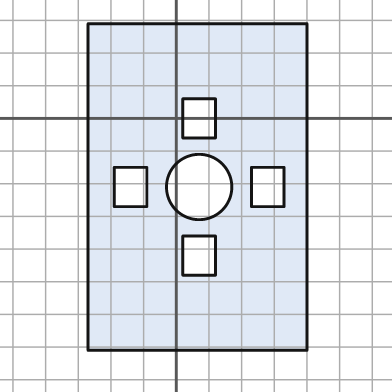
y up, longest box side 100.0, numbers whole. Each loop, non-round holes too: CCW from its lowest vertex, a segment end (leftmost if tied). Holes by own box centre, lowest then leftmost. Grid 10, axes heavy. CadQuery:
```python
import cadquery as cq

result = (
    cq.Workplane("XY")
    .moveTo(-27.0, -71.0)
    .lineTo(40.0, -71.0)
    .lineTo(40.0, 29.0)
    .lineTo(-27.0, 29.0)
    .close()
    .moveTo(2.0, -48.0)
    .lineTo(12.0, -48.0)
    .lineTo(12.0, -36.0)
    .lineTo(2.0, -36.0)
    .close()
    .moveTo(-19.0, -27.0)
    .lineTo(-9.0, -27.0)
    .lineTo(-9.0, -15.0)
    .lineTo(-19.0, -15.0)
    .close()
    .moveTo(7.0, -21.0)
    .circle(10.0)
    .moveTo(23.0, -27.0)
    .lineTo(33.0, -27.0)
    .lineTo(33.0, -15.0)
    .lineTo(23.0, -15.0)
    .close()
    .moveTo(2.0, -6.0)
    .lineTo(12.0, -6.0)
    .lineTo(12.0, 6.0)
    .lineTo(2.0, 6.0)
    .close()
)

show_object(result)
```